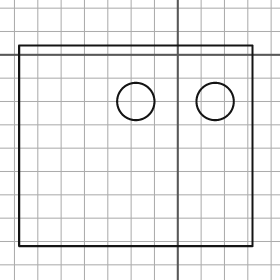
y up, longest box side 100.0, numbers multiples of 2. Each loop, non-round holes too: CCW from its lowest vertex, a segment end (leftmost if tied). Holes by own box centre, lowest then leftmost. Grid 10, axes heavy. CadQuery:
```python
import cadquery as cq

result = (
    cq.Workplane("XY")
    .moveTo(-68.0, -82.0)
    .lineTo(32.0, -82.0)
    .lineTo(32.0, 4.0)
    .lineTo(-68.0, 4.0)
    .close()
    .moveTo(-18.0, -20.0)
    .circle(8.0)
    .moveTo(16.0, -20.0)
    .circle(8.0)
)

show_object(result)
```